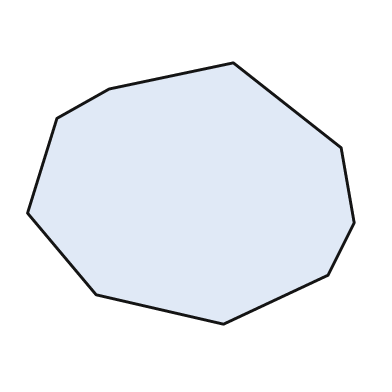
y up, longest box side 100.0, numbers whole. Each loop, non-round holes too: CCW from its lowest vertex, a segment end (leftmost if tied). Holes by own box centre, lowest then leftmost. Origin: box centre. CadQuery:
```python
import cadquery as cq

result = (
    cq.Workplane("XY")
    .moveTo(10.0, -40.0)
    .lineTo(42.0, -25.0)
    .lineTo(50.0, -9.0)
    .lineTo(46.0, 14.0)
    .lineTo(13.0, 40.0)
    .lineTo(-25.0, 32.0)
    .lineTo(-41.0, 23.0)
    .lineTo(-50.0, -6.0)
    .lineTo(-29.0, -31.0)
    .close()
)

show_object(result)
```